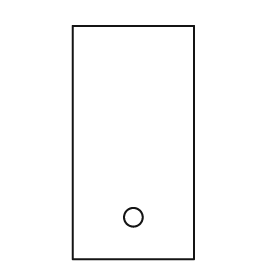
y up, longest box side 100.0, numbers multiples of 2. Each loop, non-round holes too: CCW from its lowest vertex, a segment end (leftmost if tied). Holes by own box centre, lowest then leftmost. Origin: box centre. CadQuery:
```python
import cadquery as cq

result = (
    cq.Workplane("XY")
    .moveTo(-26.0, -50.0)
    .lineTo(26.0, -50.0)
    .lineTo(26.0, 50.0)
    .lineTo(-26.0, 50.0)
    .close()
    .moveTo(0.0, -32.0)
    .circle(4.0)
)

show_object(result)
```